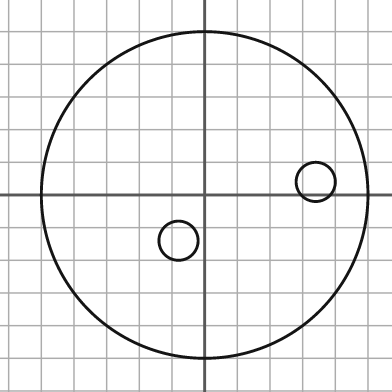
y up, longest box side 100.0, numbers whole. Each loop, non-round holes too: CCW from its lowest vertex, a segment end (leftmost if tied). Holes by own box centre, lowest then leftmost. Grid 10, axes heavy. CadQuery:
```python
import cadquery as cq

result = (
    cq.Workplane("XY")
    .moveTo(0.0, 0.0)
    .circle(50.0)
    .moveTo(-8.0, -14.0)
    .circle(6.0)
    .moveTo(34.0, 4.0)
    .circle(6.0)
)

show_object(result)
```